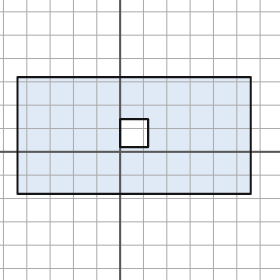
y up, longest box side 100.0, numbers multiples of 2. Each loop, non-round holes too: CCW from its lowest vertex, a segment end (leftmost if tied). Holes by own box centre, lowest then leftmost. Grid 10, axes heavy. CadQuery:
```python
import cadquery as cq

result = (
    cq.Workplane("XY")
    .moveTo(-44.0, -18.0)
    .lineTo(56.0, -18.0)
    .lineTo(56.0, 32.0)
    .lineTo(-44.0, 32.0)
    .close()
    .moveTo(0.0, 2.0)
    .lineTo(12.0, 2.0)
    .lineTo(12.0, 14.0)
    .lineTo(0.0, 14.0)
    .close()
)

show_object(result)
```